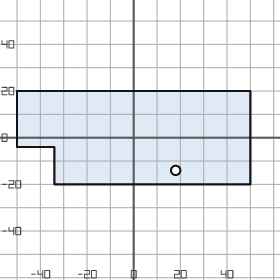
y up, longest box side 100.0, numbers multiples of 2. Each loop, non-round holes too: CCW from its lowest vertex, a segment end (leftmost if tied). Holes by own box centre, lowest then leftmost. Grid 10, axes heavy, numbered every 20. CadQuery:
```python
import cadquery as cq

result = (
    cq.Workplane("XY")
    .moveTo(-34.0, -20.0)
    .lineTo(50.0, -20.0)
    .lineTo(50.0, 20.0)
    .lineTo(-50.0, 20.0)
    .lineTo(-50.0, -4.0)
    .lineTo(-34.0, -4.0)
    .close()
    .moveTo(18.0, -14.0)
    .circle(2.0)
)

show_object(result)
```